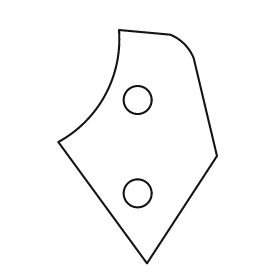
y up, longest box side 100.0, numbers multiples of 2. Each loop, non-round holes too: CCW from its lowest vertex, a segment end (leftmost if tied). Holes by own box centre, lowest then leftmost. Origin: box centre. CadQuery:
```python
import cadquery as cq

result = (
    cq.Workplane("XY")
    .moveTo(4.0, -50.0)
    .lineTo(34.0, -4.0)
    .lineTo(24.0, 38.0)
    .threePointArc((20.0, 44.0), (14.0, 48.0))
    .lineTo(-8.0, 50.0)
    .threePointArc((-14.0, 22.0), (-34.0, 2.0))
    .close()
    .moveTo(0.0, -20.0)
    .circle(6.0)
    .moveTo(0.0, 20.0)
    .circle(6.0)
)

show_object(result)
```